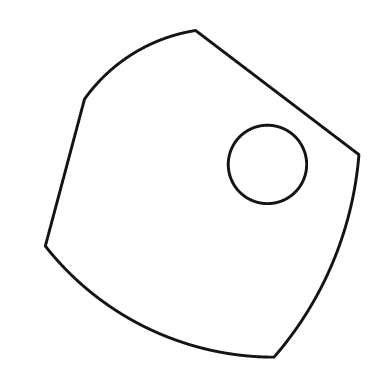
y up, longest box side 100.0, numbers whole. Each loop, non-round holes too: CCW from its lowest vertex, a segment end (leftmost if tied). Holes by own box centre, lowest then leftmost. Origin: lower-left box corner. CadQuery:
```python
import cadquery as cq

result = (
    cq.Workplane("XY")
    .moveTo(70.0, 0.0)
    .threePointArc((88.0, 29.0), (96.0, 62.0))
    .lineTo(46.0, 100.0)
    .threePointArc((27.0, 93.0), (12.0, 79.0))
    .lineTo(0.0, 34.0)
    .threePointArc((31.0, 9.0), (70.0, 0.0))
    .close()
    .moveTo(68.0, 59.0)
    .circle(12.0)
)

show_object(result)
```